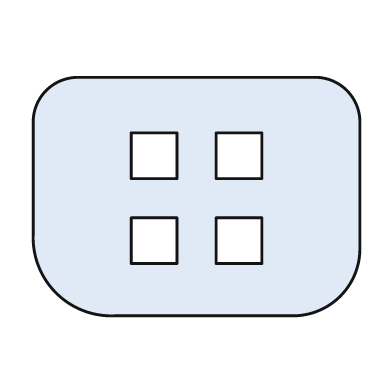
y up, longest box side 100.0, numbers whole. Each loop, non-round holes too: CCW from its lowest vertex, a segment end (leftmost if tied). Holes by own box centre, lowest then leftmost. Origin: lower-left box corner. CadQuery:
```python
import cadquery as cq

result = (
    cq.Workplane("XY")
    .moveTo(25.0, 0.0)
    .lineTo(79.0, 0.0)
    .threePointArc((94.0, 6.0), (100.0, 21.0))
    .lineTo(100.0, 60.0)
    .threePointArc((96.0, 69.0), (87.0, 73.0))
    .lineTo(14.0, 73.0)
    .threePointArc((4.0, 69.0), (0.0, 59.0))
    .lineTo(0.0, 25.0)
    .threePointArc((7.0, 7.0), (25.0, 0.0))
    .close()
    .moveTo(30.0, 16.0)
    .lineTo(44.0, 16.0)
    .lineTo(44.0, 30.0)
    .lineTo(30.0, 30.0)
    .close()
    .moveTo(56.0, 16.0)
    .lineTo(70.0, 16.0)
    .lineTo(70.0, 30.0)
    .lineTo(56.0, 30.0)
    .close()
    .moveTo(30.0, 42.0)
    .lineTo(44.0, 42.0)
    .lineTo(44.0, 56.0)
    .lineTo(30.0, 56.0)
    .close()
    .moveTo(56.0, 42.0)
    .lineTo(70.0, 42.0)
    .lineTo(70.0, 56.0)
    .lineTo(56.0, 56.0)
    .close()
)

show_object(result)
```